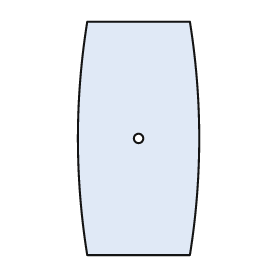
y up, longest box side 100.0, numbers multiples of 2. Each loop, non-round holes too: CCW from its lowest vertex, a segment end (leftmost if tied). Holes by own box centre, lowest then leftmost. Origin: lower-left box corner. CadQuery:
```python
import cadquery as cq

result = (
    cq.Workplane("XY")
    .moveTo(4.0, 0.0)
    .lineTo(48.0, 0.0)
    .threePointArc((52.0, 50.0), (48.0, 100.0))
    .lineTo(4.0, 100.0)
    .threePointArc((0.0, 50.0), (4.0, 0.0))
    .close()
    .moveTo(26.0, 50.0)
    .circle(2.0)
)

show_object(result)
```